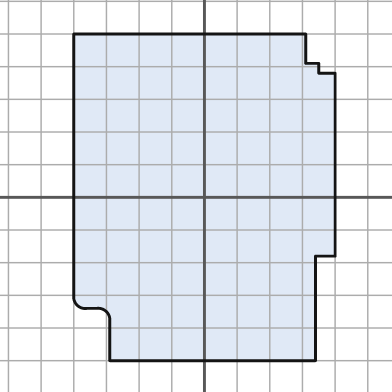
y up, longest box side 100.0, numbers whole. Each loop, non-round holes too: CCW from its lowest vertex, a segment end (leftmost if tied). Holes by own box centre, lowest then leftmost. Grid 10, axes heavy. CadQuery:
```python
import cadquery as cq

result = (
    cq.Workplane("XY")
    .moveTo(-29.0, -50.0)
    .lineTo(34.0, -50.0)
    .lineTo(34.0, -18.0)
    .lineTo(40.0, -18.0)
    .lineTo(40.0, 38.0)
    .lineTo(35.0, 38.0)
    .lineTo(35.0, 41.0)
    .lineTo(31.0, 41.0)
    .lineTo(31.0, 50.0)
    .lineTo(-40.0, 50.0)
    .lineTo(-40.0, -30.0)
    .threePointArc((-39.0, -33.0), (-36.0, -34.0))
    .lineTo(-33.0, -34.0)
    .threePointArc((-30.0, -35.0), (-29.0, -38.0))
    .close()
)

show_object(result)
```